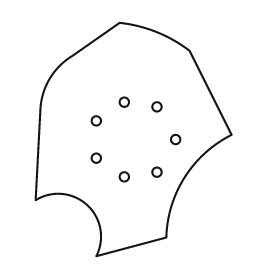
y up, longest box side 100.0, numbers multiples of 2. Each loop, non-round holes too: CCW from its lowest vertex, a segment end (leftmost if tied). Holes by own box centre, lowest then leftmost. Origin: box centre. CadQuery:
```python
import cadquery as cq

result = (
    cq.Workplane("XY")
    .moveTo(-16.0, -50.0)
    .lineTo(14.0, -42.0)
    .threePointArc((22.0, -16.0), (42.0, 2.0))
    .lineTo(24.0, 38.0)
    .threePointArc((10.0, 46.0), (-6.0, 50.0))
    .lineTo(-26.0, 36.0)
    .threePointArc((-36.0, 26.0), (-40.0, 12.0))
    .lineTo(-42.0, -26.0)
    .threePointArc((-20.0, -28.0), (-16.0, -50.0))
    .close()
    .moveTo(-4.0, -16.0)
    .circle(2.0)
    .moveTo(10.0, -14.0)
    .circle(2.0)
    .moveTo(-16.0, -8.0)
    .circle(2.0)
    .moveTo(18.0, 0.0)
    .circle(2.0)
    .moveTo(-16.0, 8.0)
    .circle(2.0)
    .moveTo(10.0, 14.0)
    .circle(2.0)
    .moveTo(-4.0, 16.0)
    .circle(2.0)
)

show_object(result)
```